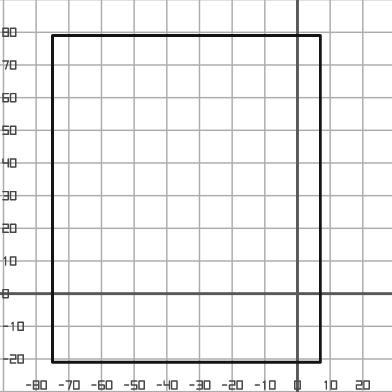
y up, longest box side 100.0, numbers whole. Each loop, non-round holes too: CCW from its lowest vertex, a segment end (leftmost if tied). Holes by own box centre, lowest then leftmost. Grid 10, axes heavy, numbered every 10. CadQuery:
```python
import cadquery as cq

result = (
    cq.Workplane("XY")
    .moveTo(-75.0, -21.0)
    .lineTo(7.0, -21.0)
    .lineTo(7.0, 79.0)
    .lineTo(-75.0, 79.0)
    .close()
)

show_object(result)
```